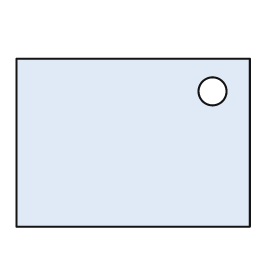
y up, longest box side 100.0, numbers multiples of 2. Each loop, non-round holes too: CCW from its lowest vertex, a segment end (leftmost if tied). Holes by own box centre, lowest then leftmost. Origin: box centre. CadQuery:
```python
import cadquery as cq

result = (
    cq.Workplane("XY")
    .moveTo(-50.0, -36.0)
    .lineTo(50.0, -36.0)
    .lineTo(50.0, 36.0)
    .lineTo(-50.0, 36.0)
    .close()
    .moveTo(34.0, 22.0)
    .circle(6.0)
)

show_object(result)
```